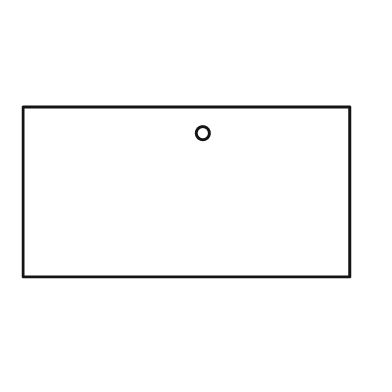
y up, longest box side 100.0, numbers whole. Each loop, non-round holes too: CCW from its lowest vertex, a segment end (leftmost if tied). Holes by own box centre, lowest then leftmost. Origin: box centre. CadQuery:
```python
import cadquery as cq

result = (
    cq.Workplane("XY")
    .moveTo(-50.0, -26.0)
    .lineTo(50.0, -26.0)
    .lineTo(50.0, 26.0)
    .lineTo(-50.0, 26.0)
    .close()
    .moveTo(5.0, 18.0)
    .circle(2.0)
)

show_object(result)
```